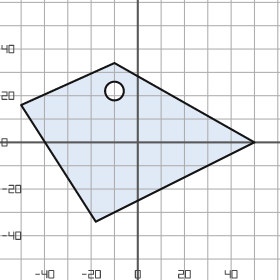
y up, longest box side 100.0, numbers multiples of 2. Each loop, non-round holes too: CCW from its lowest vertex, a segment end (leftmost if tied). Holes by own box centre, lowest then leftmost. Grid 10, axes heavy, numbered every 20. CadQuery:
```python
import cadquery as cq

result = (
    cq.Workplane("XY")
    .moveTo(-18.0, -34.0)
    .lineTo(50.0, 0.0)
    .lineTo(-10.0, 34.0)
    .lineTo(-50.0, 16.0)
    .close()
    .moveTo(-10.0, 22.0)
    .circle(4.0)
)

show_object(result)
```